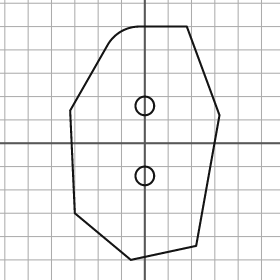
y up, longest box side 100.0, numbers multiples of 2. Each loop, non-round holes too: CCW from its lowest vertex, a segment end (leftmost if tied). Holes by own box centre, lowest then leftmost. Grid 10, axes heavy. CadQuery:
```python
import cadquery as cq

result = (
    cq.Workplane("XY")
    .moveTo(-6.0, -50.0)
    .lineTo(22.0, -44.0)
    .lineTo(32.0, 12.0)
    .lineTo(18.0, 50.0)
    .lineTo(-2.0, 50.0)
    .threePointArc((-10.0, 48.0), (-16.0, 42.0))
    .lineTo(-32.0, 14.0)
    .lineTo(-30.0, -30.0)
    .close()
    .moveTo(0.0, -14.0)
    .circle(4.0)
    .moveTo(0.0, 16.0)
    .circle(4.0)
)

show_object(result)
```